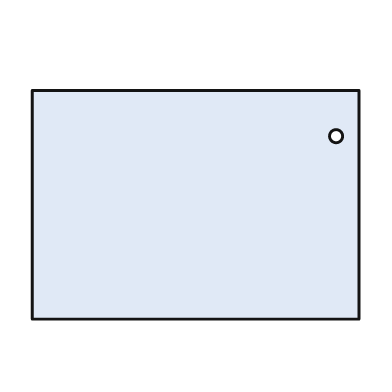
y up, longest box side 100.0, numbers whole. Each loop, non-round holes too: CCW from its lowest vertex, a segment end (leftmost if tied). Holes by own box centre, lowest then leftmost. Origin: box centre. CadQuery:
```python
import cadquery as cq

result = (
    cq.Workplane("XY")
    .moveTo(-50.0, -35.0)
    .lineTo(50.0, -35.0)
    .lineTo(50.0, 35.0)
    .lineTo(-50.0, 35.0)
    .close()
    .moveTo(43.0, 21.0)
    .circle(2.0)
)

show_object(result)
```